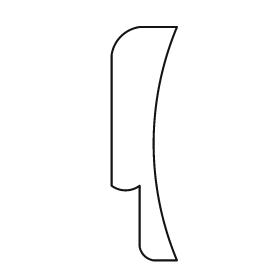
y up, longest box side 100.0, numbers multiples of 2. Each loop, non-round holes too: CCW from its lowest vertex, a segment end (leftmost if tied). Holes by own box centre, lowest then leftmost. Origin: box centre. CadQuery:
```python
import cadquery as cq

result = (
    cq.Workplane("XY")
    .moveTo(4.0, -50.0)
    .lineTo(14.0, -50.0)
    .threePointArc((4.0, 0.0), (14.0, 50.0))
    .lineTo(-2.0, 50.0)
    .threePointArc((-10.0, 46.0), (-14.0, 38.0))
    .lineTo(-14.0, -18.0)
    .threePointArc((-8.0, -20.0), (-2.0, -18.0))
    .lineTo(-2.0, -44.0)
    .threePointArc((0.0, -48.0), (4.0, -50.0))
    .close()
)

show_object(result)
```